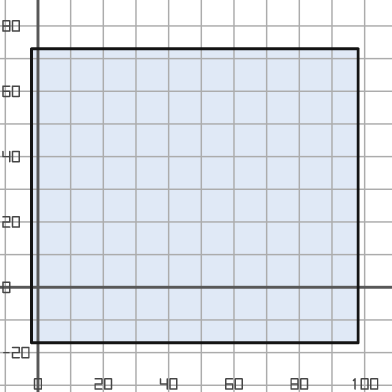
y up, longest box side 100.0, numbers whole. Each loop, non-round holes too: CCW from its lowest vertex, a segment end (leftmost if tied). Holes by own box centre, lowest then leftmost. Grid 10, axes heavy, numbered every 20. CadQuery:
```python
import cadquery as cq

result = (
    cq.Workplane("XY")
    .moveTo(-2.0, -17.0)
    .lineTo(98.0, -17.0)
    .lineTo(98.0, 73.0)
    .lineTo(-2.0, 73.0)
    .close()
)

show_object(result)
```